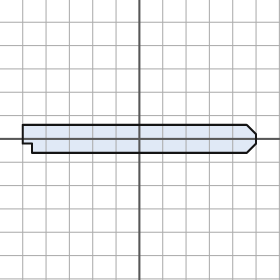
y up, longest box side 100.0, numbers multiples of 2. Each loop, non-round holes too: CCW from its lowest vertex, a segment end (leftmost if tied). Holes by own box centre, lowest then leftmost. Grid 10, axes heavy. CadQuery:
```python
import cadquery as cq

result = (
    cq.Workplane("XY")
    .moveTo(-46.0, -6.0)
    .lineTo(46.0, -6.0)
    .lineTo(50.0, -2.0)
    .lineTo(50.0, 2.0)
    .lineTo(46.0, 6.0)
    .lineTo(-50.0, 6.0)
    .lineTo(-50.0, -2.0)
    .lineTo(-46.0, -2.0)
    .close()
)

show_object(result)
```